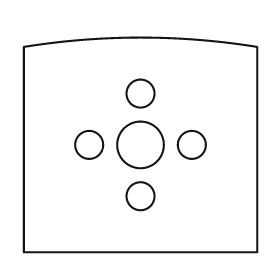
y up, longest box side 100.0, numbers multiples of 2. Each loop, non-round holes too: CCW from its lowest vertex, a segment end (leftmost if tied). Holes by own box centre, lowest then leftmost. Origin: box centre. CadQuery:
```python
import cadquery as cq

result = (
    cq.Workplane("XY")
    .moveTo(-50.0, -46.0)
    .lineTo(50.0, -46.0)
    .lineTo(50.0, 42.0)
    .threePointArc((0.0, 46.0), (-50.0, 42.0))
    .close()
    .moveTo(0.0, -22.0)
    .circle(6.0)
    .moveTo(-22.0, 0.0)
    .circle(6.0)
    .moveTo(0.0, 0.0)
    .circle(10.0)
    .moveTo(22.0, 0.0)
    .circle(6.0)
    .moveTo(0.0, 22.0)
    .circle(6.0)
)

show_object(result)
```